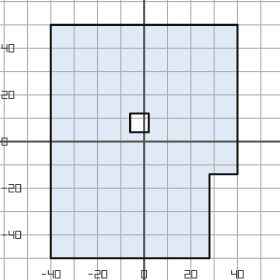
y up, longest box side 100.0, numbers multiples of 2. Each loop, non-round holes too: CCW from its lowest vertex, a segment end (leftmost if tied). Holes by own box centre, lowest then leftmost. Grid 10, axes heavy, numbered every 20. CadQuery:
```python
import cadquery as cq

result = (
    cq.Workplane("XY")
    .moveTo(-40.0, -50.0)
    .lineTo(28.0, -50.0)
    .lineTo(28.0, -14.0)
    .lineTo(40.0, -14.0)
    .lineTo(40.0, 50.0)
    .lineTo(-40.0, 50.0)
    .close()
    .moveTo(-6.0, 4.0)
    .lineTo(2.0, 4.0)
    .lineTo(2.0, 12.0)
    .lineTo(-6.0, 12.0)
    .close()
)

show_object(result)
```